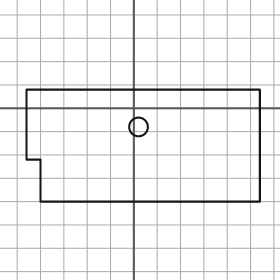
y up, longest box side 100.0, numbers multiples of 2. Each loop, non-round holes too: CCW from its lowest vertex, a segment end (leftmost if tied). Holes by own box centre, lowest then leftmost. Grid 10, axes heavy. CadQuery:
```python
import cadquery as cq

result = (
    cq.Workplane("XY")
    .moveTo(-40.0, -40.0)
    .lineTo(54.0, -40.0)
    .lineTo(54.0, 8.0)
    .lineTo(-46.0, 8.0)
    .lineTo(-46.0, -22.0)
    .lineTo(-40.0, -22.0)
    .close()
    .moveTo(2.0, -8.0)
    .circle(4.0)
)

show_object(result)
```